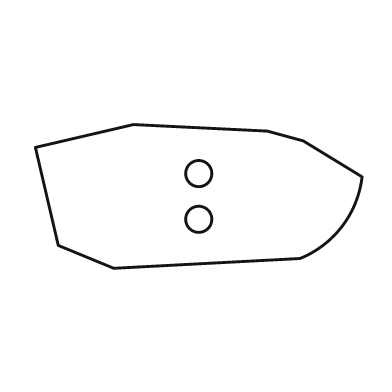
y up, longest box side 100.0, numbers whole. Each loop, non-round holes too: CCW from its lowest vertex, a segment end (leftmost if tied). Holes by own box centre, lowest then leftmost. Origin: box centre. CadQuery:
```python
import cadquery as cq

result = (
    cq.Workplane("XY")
    .moveTo(-26.0, -22.0)
    .lineTo(31.0, -19.0)
    .threePointArc((44.0, -9.0), (50.0, 6.0))
    .lineTo(32.0, 17.0)
    .lineTo(21.0, 20.0)
    .lineTo(-20.0, 22.0)
    .lineTo(-50.0, 15.0)
    .lineTo(-43.0, -15.0)
    .close()
    .moveTo(0.0, -7.0)
    .circle(4.0)
    .moveTo(0.0, 7.0)
    .circle(4.0)
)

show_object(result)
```